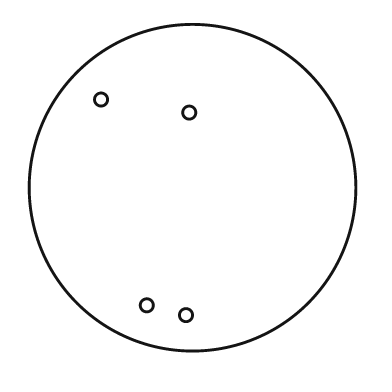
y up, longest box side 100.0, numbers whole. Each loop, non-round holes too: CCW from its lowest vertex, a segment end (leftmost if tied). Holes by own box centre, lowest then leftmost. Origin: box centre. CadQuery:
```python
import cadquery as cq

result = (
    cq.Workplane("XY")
    .moveTo(0.0, 0.0)
    .circle(50.0)
    .moveTo(-2.0, -39.0)
    .circle(2.0)
    .moveTo(-14.0, -36.0)
    .circle(2.0)
    .moveTo(-1.0, 23.0)
    .circle(2.0)
    .moveTo(-28.0, 27.0)
    .circle(2.0)
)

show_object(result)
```